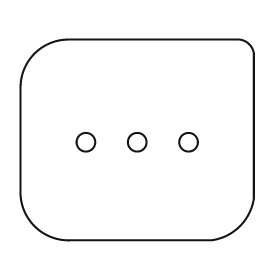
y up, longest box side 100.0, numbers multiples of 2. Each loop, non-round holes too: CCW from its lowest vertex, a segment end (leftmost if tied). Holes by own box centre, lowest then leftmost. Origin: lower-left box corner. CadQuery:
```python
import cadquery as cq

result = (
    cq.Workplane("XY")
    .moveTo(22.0, 0.0)
    .lineTo(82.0, 0.0)
    .threePointArc((94.0, 6.0), (100.0, 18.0))
    .lineTo(100.0, 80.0)
    .threePointArc((98.0, 84.0), (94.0, 86.0))
    .lineTo(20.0, 86.0)
    .threePointArc((6.0, 80.0), (0.0, 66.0))
    .lineTo(0.0, 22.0)
    .threePointArc((6.0, 6.0), (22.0, 0.0))
    .close()
    .moveTo(28.0, 42.0)
    .circle(4.0)
    .moveTo(50.0, 42.0)
    .circle(4.0)
    .moveTo(72.0, 42.0)
    .circle(4.0)
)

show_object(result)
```